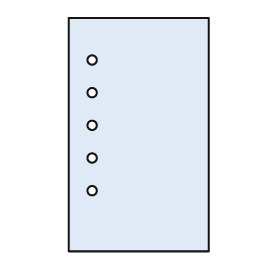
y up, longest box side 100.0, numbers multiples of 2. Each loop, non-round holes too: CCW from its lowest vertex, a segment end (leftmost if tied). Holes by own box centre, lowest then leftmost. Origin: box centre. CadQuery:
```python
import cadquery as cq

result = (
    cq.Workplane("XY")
    .moveTo(-30.0, -50.0)
    .lineTo(30.0, -50.0)
    .lineTo(30.0, 50.0)
    .lineTo(-30.0, 50.0)
    .close()
    .moveTo(-20.0, -24.0)
    .circle(2.0)
    .moveTo(-20.0, -10.0)
    .circle(2.0)
    .moveTo(-20.0, 4.0)
    .circle(2.0)
    .moveTo(-20.0, 18.0)
    .circle(2.0)
    .moveTo(-20.0, 32.0)
    .circle(2.0)
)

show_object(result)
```